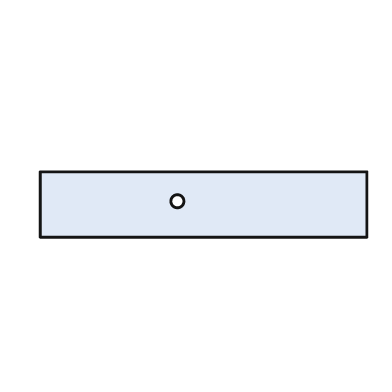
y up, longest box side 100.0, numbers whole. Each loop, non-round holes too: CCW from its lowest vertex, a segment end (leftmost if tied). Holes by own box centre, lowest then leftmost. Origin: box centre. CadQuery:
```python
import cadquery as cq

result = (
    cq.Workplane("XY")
    .moveTo(-50.0, -10.0)
    .lineTo(50.0, -10.0)
    .lineTo(50.0, 10.0)
    .lineTo(-50.0, 10.0)
    .close()
    .moveTo(-8.0, 1.0)
    .circle(2.0)
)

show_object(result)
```